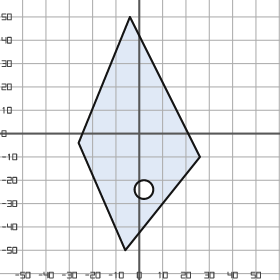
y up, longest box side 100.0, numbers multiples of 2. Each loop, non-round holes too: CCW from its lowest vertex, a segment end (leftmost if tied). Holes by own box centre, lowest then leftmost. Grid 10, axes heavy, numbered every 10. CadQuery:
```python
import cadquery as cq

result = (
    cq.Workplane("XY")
    .moveTo(-6.0, -50.0)
    .lineTo(26.0, -10.0)
    .lineTo(-4.0, 50.0)
    .lineTo(-26.0, -4.0)
    .close()
    .moveTo(2.0, -24.0)
    .circle(4.0)
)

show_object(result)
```